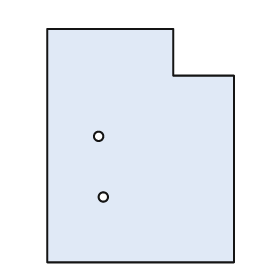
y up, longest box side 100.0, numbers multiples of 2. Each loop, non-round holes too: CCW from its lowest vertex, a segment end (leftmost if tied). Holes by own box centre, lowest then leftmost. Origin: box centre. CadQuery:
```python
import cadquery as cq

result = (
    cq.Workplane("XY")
    .moveTo(-40.0, -50.0)
    .lineTo(40.0, -50.0)
    .lineTo(40.0, 30.0)
    .lineTo(14.0, 30.0)
    .lineTo(14.0, 50.0)
    .lineTo(-40.0, 50.0)
    .close()
    .moveTo(-16.0, -22.0)
    .circle(2.0)
    .moveTo(-18.0, 4.0)
    .circle(2.0)
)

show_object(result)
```